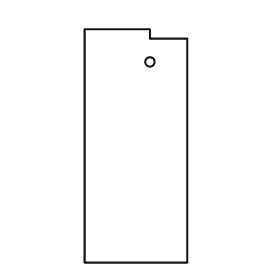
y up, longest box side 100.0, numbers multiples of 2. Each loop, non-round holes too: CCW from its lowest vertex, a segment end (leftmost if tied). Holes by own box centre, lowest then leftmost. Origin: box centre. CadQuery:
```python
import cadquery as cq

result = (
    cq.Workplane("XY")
    .moveTo(-22.0, -50.0)
    .lineTo(22.0, -50.0)
    .lineTo(22.0, 46.0)
    .lineTo(6.0, 46.0)
    .lineTo(6.0, 50.0)
    .lineTo(-22.0, 50.0)
    .close()
    .moveTo(6.0, 36.0)
    .circle(2.0)
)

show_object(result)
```